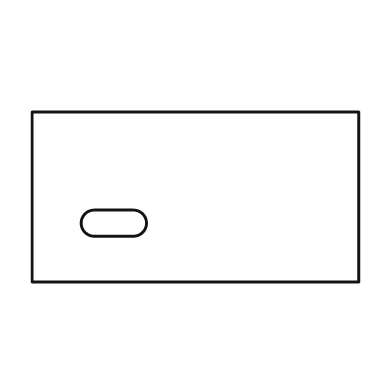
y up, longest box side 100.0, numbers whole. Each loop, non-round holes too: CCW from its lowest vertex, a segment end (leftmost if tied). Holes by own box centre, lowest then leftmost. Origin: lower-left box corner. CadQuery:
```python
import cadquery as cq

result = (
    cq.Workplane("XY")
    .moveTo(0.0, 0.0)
    .lineTo(100.0, 0.0)
    .lineTo(100.0, 52.0)
    .lineTo(0.0, 52.0)
    .close()
    .moveTo(19.0, 14.0)
    .lineTo(31.0, 14.0)
    .threePointArc((35.0, 18.0), (31.0, 22.0))
    .lineTo(19.0, 22.0)
    .threePointArc((15.0, 18.0), (19.0, 14.0))
    .close()
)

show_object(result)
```